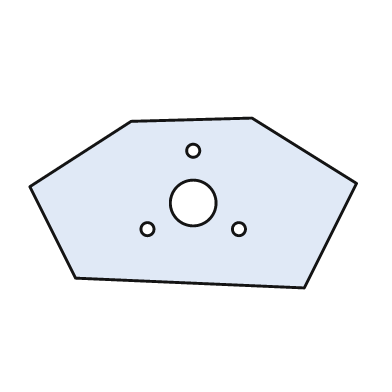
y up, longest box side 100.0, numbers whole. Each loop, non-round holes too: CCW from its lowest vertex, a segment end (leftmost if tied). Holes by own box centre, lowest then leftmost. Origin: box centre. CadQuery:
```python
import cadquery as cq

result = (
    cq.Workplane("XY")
    .moveTo(34.0, -26.0)
    .lineTo(50.0, 6.0)
    .lineTo(18.0, 26.0)
    .lineTo(-19.0, 25.0)
    .lineTo(-50.0, 5.0)
    .lineTo(-36.0, -23.0)
    .close()
    .moveTo(-14.0, -8.0)
    .circle(2.0)
    .moveTo(14.0, -8.0)
    .circle(2.0)
    .moveTo(0.0, 0.0)
    .circle(7.0)
    .moveTo(0.0, 16.0)
    .circle(2.0)
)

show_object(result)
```